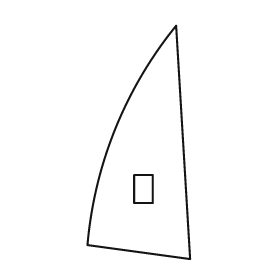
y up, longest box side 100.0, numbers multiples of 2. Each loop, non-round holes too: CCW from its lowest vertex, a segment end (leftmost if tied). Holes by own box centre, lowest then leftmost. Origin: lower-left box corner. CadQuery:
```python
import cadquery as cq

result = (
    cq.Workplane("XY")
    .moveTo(44.0, 0.0)
    .lineTo(38.0, 100.0)
    .threePointArc((12.0, 56.0), (0.0, 6.0))
    .close()
    .moveTo(20.0, 24.0)
    .lineTo(28.0, 24.0)
    .lineTo(28.0, 36.0)
    .lineTo(20.0, 36.0)
    .close()
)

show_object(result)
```